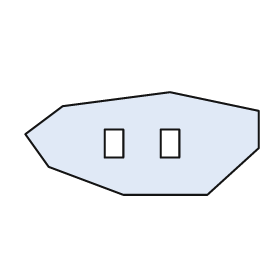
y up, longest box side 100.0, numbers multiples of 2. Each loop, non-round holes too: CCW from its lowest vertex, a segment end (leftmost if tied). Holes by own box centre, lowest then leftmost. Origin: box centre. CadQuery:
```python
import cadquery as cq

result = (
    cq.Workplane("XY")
    .moveTo(-8.0, -22.0)
    .lineTo(28.0, -22.0)
    .lineTo(50.0, -2.0)
    .lineTo(50.0, 14.0)
    .lineTo(12.0, 22.0)
    .lineTo(-34.0, 16.0)
    .lineTo(-50.0, 4.0)
    .lineTo(-40.0, -10.0)
    .close()
    .moveTo(-16.0, -6.0)
    .lineTo(-8.0, -6.0)
    .lineTo(-8.0, 6.0)
    .lineTo(-16.0, 6.0)
    .close()
    .moveTo(8.0, -6.0)
    .lineTo(16.0, -6.0)
    .lineTo(16.0, 6.0)
    .lineTo(8.0, 6.0)
    .close()
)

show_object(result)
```